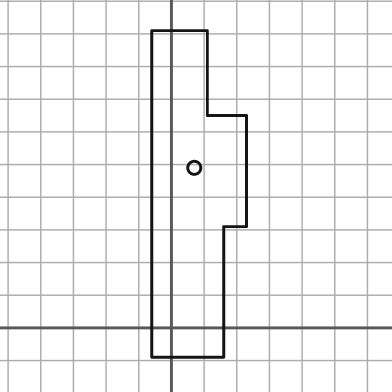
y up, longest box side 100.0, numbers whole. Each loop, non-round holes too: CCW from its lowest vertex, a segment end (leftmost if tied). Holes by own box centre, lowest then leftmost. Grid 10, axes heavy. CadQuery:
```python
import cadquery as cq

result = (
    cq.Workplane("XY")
    .moveTo(-6.0, -9.0)
    .lineTo(16.0, -9.0)
    .lineTo(16.0, 31.0)
    .lineTo(23.0, 31.0)
    .lineTo(23.0, 65.0)
    .lineTo(11.0, 65.0)
    .lineTo(11.0, 91.0)
    .lineTo(-6.0, 91.0)
    .close()
    .moveTo(7.0, 49.0)
    .circle(2.0)
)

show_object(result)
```